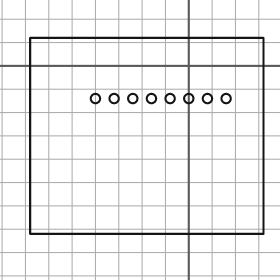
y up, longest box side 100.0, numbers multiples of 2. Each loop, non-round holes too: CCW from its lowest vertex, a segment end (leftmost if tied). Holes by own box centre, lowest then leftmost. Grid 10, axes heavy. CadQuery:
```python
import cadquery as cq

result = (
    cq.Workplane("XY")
    .moveTo(-68.0, -72.0)
    .lineTo(32.0, -72.0)
    .lineTo(32.0, 12.0)
    .lineTo(-68.0, 12.0)
    .close()
    .moveTo(-40.0, -14.0)
    .circle(2.0)
    .moveTo(-32.0, -14.0)
    .circle(2.0)
    .moveTo(-24.0, -14.0)
    .circle(2.0)
    .moveTo(-16.0, -14.0)
    .circle(2.0)
    .moveTo(-8.0, -14.0)
    .circle(2.0)
    .moveTo(0.0, -14.0)
    .circle(2.0)
    .moveTo(8.0, -14.0)
    .circle(2.0)
    .moveTo(16.0, -14.0)
    .circle(2.0)
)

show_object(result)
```